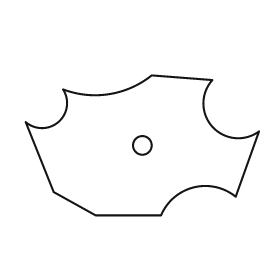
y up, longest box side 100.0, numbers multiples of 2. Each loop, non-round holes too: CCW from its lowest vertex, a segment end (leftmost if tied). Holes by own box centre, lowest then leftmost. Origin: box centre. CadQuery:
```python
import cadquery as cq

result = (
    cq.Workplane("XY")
    .moveTo(-20.0, -30.0)
    .lineTo(8.0, -30.0)
    .threePointArc((22.0, -18.0), (40.0, -22.0))
    .lineTo(50.0, 6.0)
    .threePointArc((30.0, 8.0), (30.0, 28.0))
    .lineTo(4.0, 30.0)
    .threePointArc((-14.0, 22.0), (-34.0, 24.0))
    .threePointArc((-36.0, 10.0), (-50.0, 10.0))
    .lineTo(-38.0, -20.0)
    .close()
    .moveTo(0.0, 0.0)
    .circle(4.0)
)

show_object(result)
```